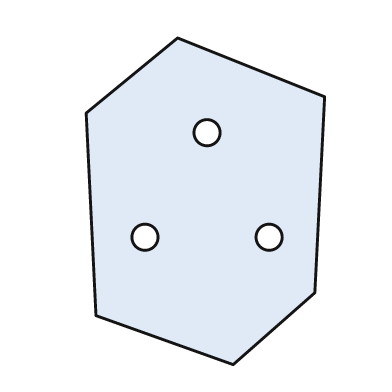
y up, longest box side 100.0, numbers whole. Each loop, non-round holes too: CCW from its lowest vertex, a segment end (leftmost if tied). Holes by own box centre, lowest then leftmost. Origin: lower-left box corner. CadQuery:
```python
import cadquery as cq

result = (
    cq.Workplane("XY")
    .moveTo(45.0, 0.0)
    .lineTo(70.0, 22.0)
    .lineTo(73.0, 82.0)
    .lineTo(28.0, 100.0)
    .lineTo(0.0, 77.0)
    .lineTo(3.0, 15.0)
    .close()
    .moveTo(18.0, 39.0)
    .circle(4.0)
    .moveTo(56.0, 39.0)
    .circle(4.0)
    .moveTo(37.0, 71.0)
    .circle(4.0)
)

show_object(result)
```